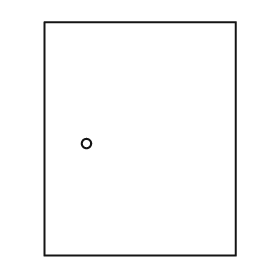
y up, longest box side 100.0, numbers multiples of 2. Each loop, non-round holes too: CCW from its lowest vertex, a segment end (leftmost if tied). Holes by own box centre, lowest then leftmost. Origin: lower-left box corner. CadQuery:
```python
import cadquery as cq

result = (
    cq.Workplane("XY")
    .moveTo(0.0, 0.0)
    .lineTo(82.0, 0.0)
    .lineTo(82.0, 100.0)
    .lineTo(0.0, 100.0)
    .close()
    .moveTo(18.0, 48.0)
    .circle(2.0)
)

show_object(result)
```